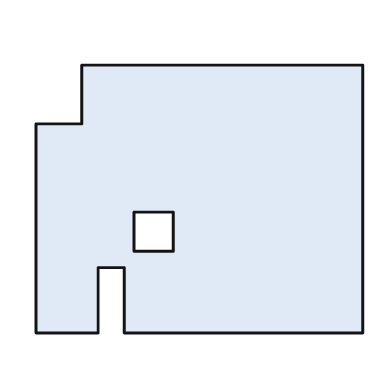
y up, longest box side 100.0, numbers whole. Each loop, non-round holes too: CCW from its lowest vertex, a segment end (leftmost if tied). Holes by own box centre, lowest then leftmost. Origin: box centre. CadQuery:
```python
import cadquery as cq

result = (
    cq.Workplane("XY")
    .moveTo(-50.0, -41.0)
    .lineTo(-31.0, -41.0)
    .lineTo(-31.0, -21.0)
    .lineTo(-23.0, -21.0)
    .lineTo(-23.0, -41.0)
    .lineTo(50.0, -41.0)
    .lineTo(50.0, 41.0)
    .lineTo(-36.0, 41.0)
    .lineTo(-36.0, 23.0)
    .lineTo(-50.0, 23.0)
    .close()
    .moveTo(-20.0, -16.0)
    .lineTo(-8.0, -16.0)
    .lineTo(-8.0, -4.0)
    .lineTo(-20.0, -4.0)
    .close()
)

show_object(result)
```